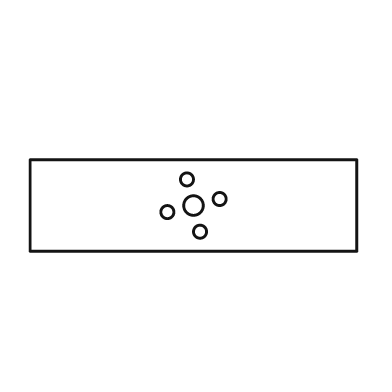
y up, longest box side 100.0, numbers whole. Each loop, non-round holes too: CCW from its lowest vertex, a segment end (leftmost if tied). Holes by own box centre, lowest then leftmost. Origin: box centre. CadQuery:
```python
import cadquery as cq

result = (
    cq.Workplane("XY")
    .moveTo(-50.0, -14.0)
    .lineTo(50.0, -14.0)
    .lineTo(50.0, 14.0)
    .lineTo(-50.0, 14.0)
    .close()
    .moveTo(2.0, -8.0)
    .circle(2.0)
    .moveTo(-8.0, -2.0)
    .circle(2.0)
    .moveTo(0.0, 0.0)
    .circle(3.0)
    .moveTo(8.0, 2.0)
    .circle(2.0)
    .moveTo(-2.0, 8.0)
    .circle(2.0)
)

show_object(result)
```